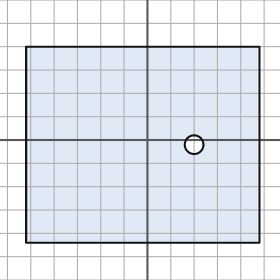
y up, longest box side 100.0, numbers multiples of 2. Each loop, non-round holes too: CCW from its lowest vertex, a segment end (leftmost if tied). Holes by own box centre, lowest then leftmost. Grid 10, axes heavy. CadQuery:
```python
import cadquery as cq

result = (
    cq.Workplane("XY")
    .moveTo(-52.0, -44.0)
    .lineTo(48.0, -44.0)
    .lineTo(48.0, 40.0)
    .lineTo(-52.0, 40.0)
    .close()
    .moveTo(20.0, -2.0)
    .circle(4.0)
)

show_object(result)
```